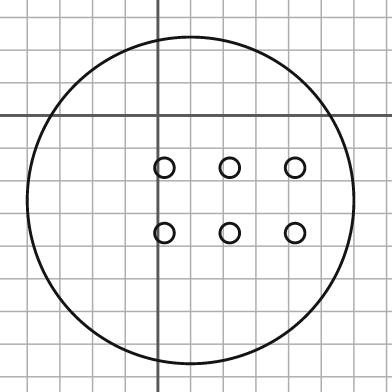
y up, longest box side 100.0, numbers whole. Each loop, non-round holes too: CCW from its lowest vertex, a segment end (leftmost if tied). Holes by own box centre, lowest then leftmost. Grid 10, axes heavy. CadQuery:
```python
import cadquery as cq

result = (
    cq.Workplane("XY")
    .moveTo(10.0, -26.0)
    .circle(50.0)
    .moveTo(2.0, -36.0)
    .circle(3.0)
    .moveTo(22.0, -36.0)
    .circle(3.0)
    .moveTo(42.0, -36.0)
    .circle(3.0)
    .moveTo(2.0, -16.0)
    .circle(3.0)
    .moveTo(22.0, -16.0)
    .circle(3.0)
    .moveTo(42.0, -16.0)
    .circle(3.0)
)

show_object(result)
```